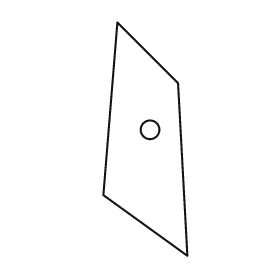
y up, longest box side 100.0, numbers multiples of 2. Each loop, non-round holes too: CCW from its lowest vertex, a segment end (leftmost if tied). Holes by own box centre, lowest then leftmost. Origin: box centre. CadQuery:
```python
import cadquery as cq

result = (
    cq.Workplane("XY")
    .moveTo(18.0, -50.0)
    .lineTo(14.0, 24.0)
    .lineTo(-12.0, 50.0)
    .lineTo(-18.0, -24.0)
    .close()
    .moveTo(2.0, 4.0)
    .circle(4.0)
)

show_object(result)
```